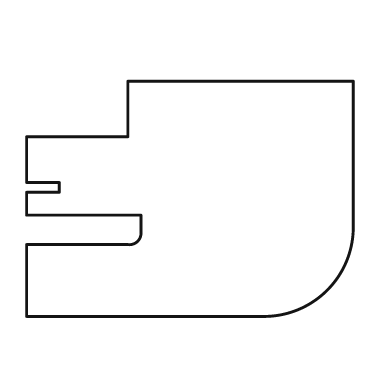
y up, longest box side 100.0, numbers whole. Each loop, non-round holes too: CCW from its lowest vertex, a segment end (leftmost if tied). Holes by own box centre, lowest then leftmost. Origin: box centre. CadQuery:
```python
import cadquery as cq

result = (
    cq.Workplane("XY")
    .moveTo(-50.0, -36.0)
    .lineTo(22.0, -36.0)
    .threePointArc((42.0, -28.0), (50.0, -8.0))
    .lineTo(50.0, 36.0)
    .lineTo(-19.0, 36.0)
    .lineTo(-19.0, 19.0)
    .lineTo(-50.0, 19.0)
    .lineTo(-50.0, 5.0)
    .lineTo(-40.0, 5.0)
    .lineTo(-40.0, 2.0)
    .lineTo(-50.0, 2.0)
    .lineTo(-50.0, -5.0)
    .lineTo(-15.0, -5.0)
    .lineTo(-15.0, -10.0)
    .threePointArc((-16.0, -13.0), (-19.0, -14.0))
    .lineTo(-50.0, -14.0)
    .close()
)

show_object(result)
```